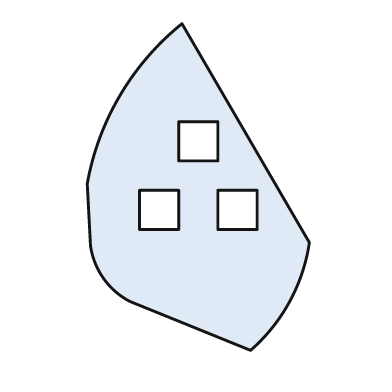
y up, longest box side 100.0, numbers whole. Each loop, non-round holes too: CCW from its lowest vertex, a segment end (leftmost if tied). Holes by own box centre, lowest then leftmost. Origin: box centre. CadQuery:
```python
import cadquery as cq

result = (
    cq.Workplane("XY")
    .moveTo(16.0, -50.0)
    .threePointArc((28.0, -35.0), (34.0, -17.0))
    .lineTo(-5.0, 50.0)
    .threePointArc((-24.0, 28.0), (-34.0, 1.0))
    .lineTo(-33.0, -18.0)
    .threePointArc((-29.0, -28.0), (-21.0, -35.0))
    .close()
    .moveTo(-18.0, -13.0)
    .lineTo(-6.0, -13.0)
    .lineTo(-6.0, -1.0)
    .lineTo(-18.0, -1.0)
    .close()
    .moveTo(6.0, -13.0)
    .lineTo(18.0, -13.0)
    .lineTo(18.0, -1.0)
    .lineTo(6.0, -1.0)
    .close()
    .moveTo(-6.0, 8.0)
    .lineTo(6.0, 8.0)
    .lineTo(6.0, 20.0)
    .lineTo(-6.0, 20.0)
    .close()
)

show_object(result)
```